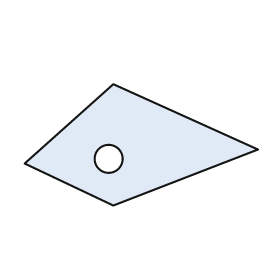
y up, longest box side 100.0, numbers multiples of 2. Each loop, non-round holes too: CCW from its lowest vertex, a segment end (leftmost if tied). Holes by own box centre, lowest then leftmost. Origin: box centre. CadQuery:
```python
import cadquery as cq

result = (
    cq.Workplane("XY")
    .moveTo(-12.0, -26.0)
    .lineTo(50.0, -2.0)
    .lineTo(-12.0, 26.0)
    .lineTo(-50.0, -8.0)
    .close()
    .moveTo(-14.0, -6.0)
    .circle(6.0)
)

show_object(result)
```